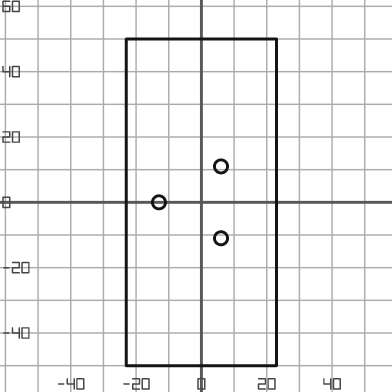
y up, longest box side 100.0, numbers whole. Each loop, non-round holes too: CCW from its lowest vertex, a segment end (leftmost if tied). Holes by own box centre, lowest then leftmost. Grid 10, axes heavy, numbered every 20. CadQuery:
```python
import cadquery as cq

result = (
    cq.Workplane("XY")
    .moveTo(-23.0, -50.0)
    .lineTo(23.0, -50.0)
    .lineTo(23.0, 50.0)
    .lineTo(-23.0, 50.0)
    .close()
    .moveTo(6.0, -11.0)
    .circle(2.0)
    .moveTo(-13.0, 0.0)
    .circle(2.0)
    .moveTo(6.0, 11.0)
    .circle(2.0)
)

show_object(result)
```